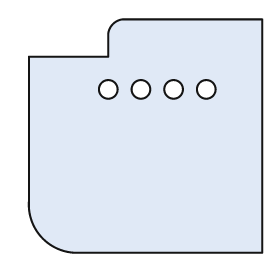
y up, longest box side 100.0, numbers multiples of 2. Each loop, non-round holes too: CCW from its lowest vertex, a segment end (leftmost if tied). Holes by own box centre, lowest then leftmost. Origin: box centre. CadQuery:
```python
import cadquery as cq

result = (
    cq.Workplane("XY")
    .moveTo(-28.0, -50.0)
    .lineTo(50.0, -50.0)
    .lineTo(50.0, 50.0)
    .lineTo(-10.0, 50.0)
    .threePointArc((-14.0, 48.0), (-16.0, 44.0))
    .lineTo(-16.0, 34.0)
    .lineTo(-50.0, 34.0)
    .lineTo(-50.0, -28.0)
    .threePointArc((-44.0, -44.0), (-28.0, -50.0))
    .close()
    .moveTo(-16.0, 20.0)
    .circle(4.0)
    .moveTo(-2.0, 20.0)
    .circle(4.0)
    .moveTo(12.0, 20.0)
    .circle(4.0)
    .moveTo(26.0, 20.0)
    .circle(4.0)
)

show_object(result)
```